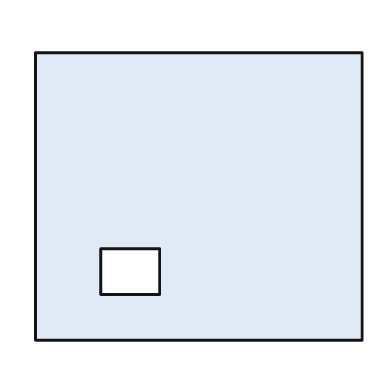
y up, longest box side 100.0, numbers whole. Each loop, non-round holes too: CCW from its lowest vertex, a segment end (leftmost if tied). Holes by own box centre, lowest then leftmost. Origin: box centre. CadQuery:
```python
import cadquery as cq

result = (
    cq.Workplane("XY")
    .moveTo(-50.0, -44.0)
    .lineTo(50.0, -44.0)
    .lineTo(50.0, 44.0)
    .lineTo(-50.0, 44.0)
    .close()
    .moveTo(-30.0, -30.0)
    .lineTo(-12.0, -30.0)
    .lineTo(-12.0, -16.0)
    .lineTo(-30.0, -16.0)
    .close()
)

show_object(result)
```